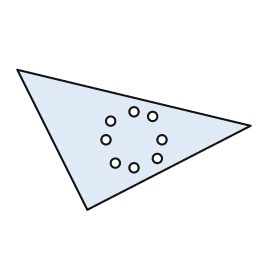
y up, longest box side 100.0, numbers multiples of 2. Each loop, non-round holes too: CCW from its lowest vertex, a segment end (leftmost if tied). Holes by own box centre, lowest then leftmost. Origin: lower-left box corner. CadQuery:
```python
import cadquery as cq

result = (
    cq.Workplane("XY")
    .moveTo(30.0, 0.0)
    .lineTo(100.0, 36.0)
    .lineTo(0.0, 60.0)
    .close()
    .moveTo(50.0, 18.0)
    .circle(2.0)
    .moveTo(42.0, 20.0)
    .circle(2.0)
    .moveTo(60.0, 22.0)
    .circle(2.0)
    .moveTo(38.0, 30.0)
    .circle(2.0)
    .moveTo(62.0, 30.0)
    .circle(2.0)
    .moveTo(40.0, 38.0)
    .circle(2.0)
    .moveTo(58.0, 40.0)
    .circle(2.0)
    .moveTo(50.0, 42.0)
    .circle(2.0)
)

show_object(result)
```